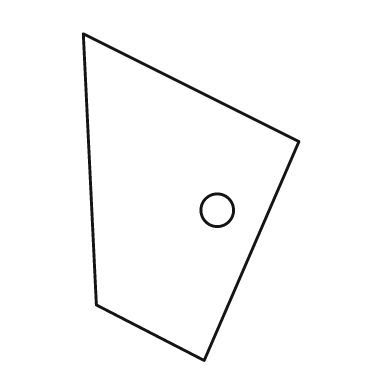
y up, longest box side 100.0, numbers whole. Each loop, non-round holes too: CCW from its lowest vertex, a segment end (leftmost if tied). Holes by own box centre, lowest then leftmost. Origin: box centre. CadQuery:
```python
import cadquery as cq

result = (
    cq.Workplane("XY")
    .moveTo(4.0, -50.0)
    .lineTo(33.0, 17.0)
    .lineTo(-33.0, 50.0)
    .lineTo(-29.0, -33.0)
    .close()
    .moveTo(8.0, -4.0)
    .circle(5.0)
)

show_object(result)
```